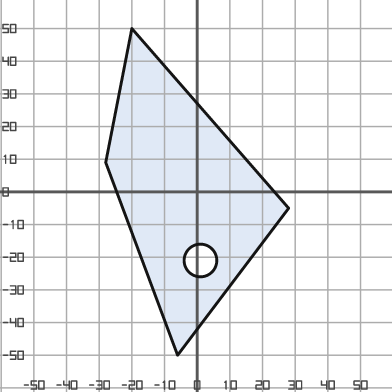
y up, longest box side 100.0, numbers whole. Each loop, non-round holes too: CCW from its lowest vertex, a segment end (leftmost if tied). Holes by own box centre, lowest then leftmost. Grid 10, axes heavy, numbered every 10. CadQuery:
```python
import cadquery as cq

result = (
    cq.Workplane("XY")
    .moveTo(-6.0, -50.0)
    .lineTo(28.0, -5.0)
    .lineTo(-20.0, 50.0)
    .lineTo(-28.0, 9.0)
    .close()
    .moveTo(1.0, -21.0)
    .circle(5.0)
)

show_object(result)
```